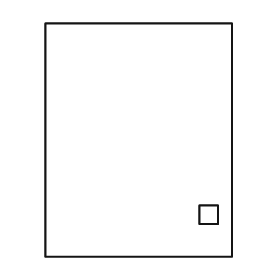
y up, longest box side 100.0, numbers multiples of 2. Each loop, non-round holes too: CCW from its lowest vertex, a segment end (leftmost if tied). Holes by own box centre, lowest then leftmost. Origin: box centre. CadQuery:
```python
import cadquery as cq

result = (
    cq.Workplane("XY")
    .moveTo(-40.0, -50.0)
    .lineTo(40.0, -50.0)
    .lineTo(40.0, 50.0)
    .lineTo(-40.0, 50.0)
    .close()
    .moveTo(26.0, -36.0)
    .lineTo(34.0, -36.0)
    .lineTo(34.0, -28.0)
    .lineTo(26.0, -28.0)
    .close()
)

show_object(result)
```